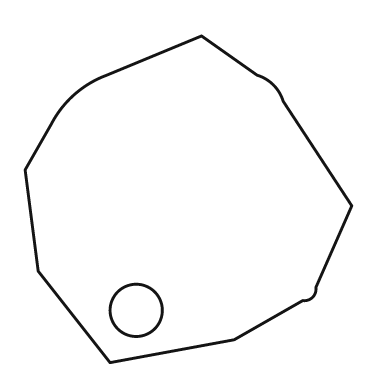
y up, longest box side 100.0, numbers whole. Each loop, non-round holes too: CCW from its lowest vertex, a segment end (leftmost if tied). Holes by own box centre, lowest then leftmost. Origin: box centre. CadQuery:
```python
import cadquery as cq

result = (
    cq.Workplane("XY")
    .moveTo(-24.0, -50.0)
    .lineTo(14.0, -43.0)
    .lineTo(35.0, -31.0)
    .threePointArc((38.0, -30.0), (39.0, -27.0))
    .lineTo(50.0, -2.0)
    .lineTo(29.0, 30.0)
    .threePointArc((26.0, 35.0), (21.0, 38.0))
    .lineTo(4.0, 50.0)
    .lineTo(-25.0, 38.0)
    .threePointArc((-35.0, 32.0), (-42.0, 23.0))
    .lineTo(-50.0, 9.0)
    .lineTo(-46.0, -22.0)
    .close()
    .moveTo(-16.0, -34.0)
    .circle(8.0)
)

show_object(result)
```